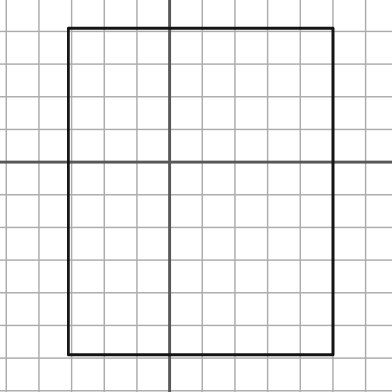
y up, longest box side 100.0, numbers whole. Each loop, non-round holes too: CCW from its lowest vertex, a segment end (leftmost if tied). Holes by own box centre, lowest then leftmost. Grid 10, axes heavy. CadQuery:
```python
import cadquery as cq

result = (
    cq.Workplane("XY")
    .moveTo(-31.0, -59.0)
    .lineTo(50.0, -59.0)
    .lineTo(50.0, 41.0)
    .lineTo(-31.0, 41.0)
    .close()
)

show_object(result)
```